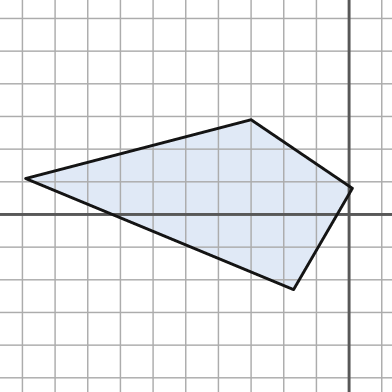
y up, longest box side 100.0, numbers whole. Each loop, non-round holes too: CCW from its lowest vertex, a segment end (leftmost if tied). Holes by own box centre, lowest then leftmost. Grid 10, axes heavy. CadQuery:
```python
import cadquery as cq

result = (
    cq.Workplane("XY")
    .moveTo(-17.0, -23.0)
    .lineTo(1.0, 8.0)
    .lineTo(-30.0, 29.0)
    .lineTo(-99.0, 11.0)
    .close()
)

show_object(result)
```